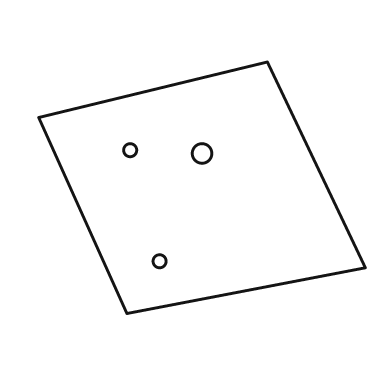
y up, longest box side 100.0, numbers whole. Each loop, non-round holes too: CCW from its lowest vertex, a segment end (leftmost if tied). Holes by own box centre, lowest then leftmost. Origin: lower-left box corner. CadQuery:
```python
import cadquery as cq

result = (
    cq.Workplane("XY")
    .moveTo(27.0, 0.0)
    .lineTo(100.0, 14.0)
    .lineTo(70.0, 77.0)
    .lineTo(0.0, 60.0)
    .close()
    .moveTo(37.0, 16.0)
    .circle(2.0)
    .moveTo(50.0, 49.0)
    .circle(3.0)
    .moveTo(28.0, 50.0)
    .circle(2.0)
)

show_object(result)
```